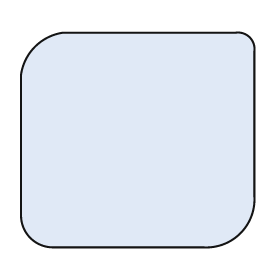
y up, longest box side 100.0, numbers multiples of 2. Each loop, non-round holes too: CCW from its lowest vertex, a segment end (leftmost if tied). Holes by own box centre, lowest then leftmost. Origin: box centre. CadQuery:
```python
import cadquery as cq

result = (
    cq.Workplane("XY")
    .moveTo(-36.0, -46.0)
    .lineTo(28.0, -46.0)
    .threePointArc((44.0, -40.0), (50.0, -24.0))
    .lineTo(50.0, 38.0)
    .threePointArc((48.0, 44.0), (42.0, 46.0))
    .lineTo(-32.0, 46.0)
    .threePointArc((-44.0, 40.0), (-50.0, 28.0))
    .lineTo(-50.0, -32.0)
    .threePointArc((-46.0, -42.0), (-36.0, -46.0))
    .close()
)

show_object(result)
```